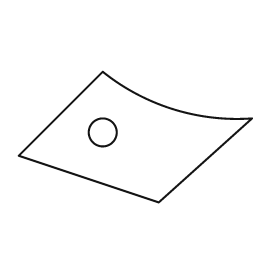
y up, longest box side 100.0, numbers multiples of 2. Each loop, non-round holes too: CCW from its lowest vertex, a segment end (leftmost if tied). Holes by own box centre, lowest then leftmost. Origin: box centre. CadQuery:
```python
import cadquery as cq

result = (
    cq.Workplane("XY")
    .moveTo(10.0, -28.0)
    .lineTo(50.0, 8.0)
    .threePointArc((16.0, 12.0), (-14.0, 28.0))
    .lineTo(-50.0, -8.0)
    .close()
    .moveTo(-14.0, 2.0)
    .circle(6.0)
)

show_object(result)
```